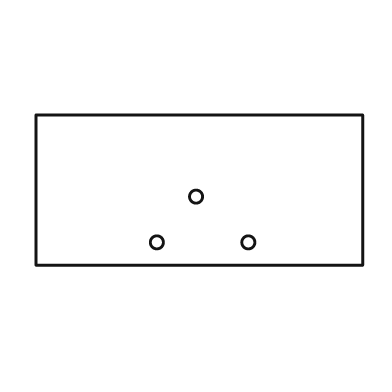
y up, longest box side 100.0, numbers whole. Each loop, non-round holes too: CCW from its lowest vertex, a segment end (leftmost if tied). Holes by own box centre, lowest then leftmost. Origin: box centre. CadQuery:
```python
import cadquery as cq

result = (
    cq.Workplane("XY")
    .moveTo(-50.0, -23.0)
    .lineTo(50.0, -23.0)
    .lineTo(50.0, 23.0)
    .lineTo(-50.0, 23.0)
    .close()
    .moveTo(-13.0, -16.0)
    .circle(2.0)
    .moveTo(15.0, -16.0)
    .circle(2.0)
    .moveTo(-1.0, -2.0)
    .circle(2.0)
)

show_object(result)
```